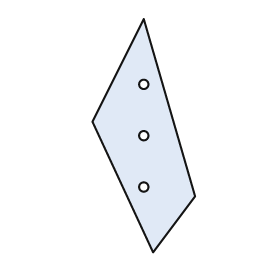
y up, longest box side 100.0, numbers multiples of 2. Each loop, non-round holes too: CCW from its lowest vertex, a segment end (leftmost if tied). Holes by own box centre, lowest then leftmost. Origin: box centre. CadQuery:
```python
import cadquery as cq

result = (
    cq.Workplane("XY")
    .moveTo(4.0, -50.0)
    .lineTo(22.0, -26.0)
    .lineTo(0.0, 50.0)
    .lineTo(-22.0, 6.0)
    .close()
    .moveTo(0.0, -22.0)
    .circle(2.0)
    .moveTo(0.0, 0.0)
    .circle(2.0)
    .moveTo(0.0, 22.0)
    .circle(2.0)
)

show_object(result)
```